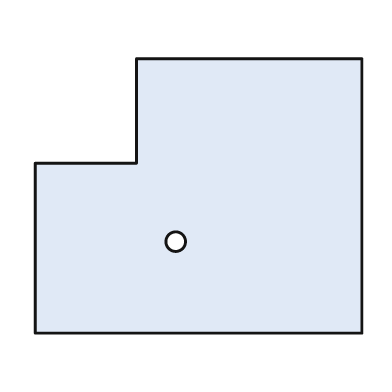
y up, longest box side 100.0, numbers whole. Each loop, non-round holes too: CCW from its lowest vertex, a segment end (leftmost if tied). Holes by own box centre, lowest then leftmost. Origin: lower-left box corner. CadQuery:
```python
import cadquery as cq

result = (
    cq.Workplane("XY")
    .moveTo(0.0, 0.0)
    .lineTo(100.0, 0.0)
    .lineTo(100.0, 84.0)
    .lineTo(31.0, 84.0)
    .lineTo(31.0, 52.0)
    .lineTo(0.0, 52.0)
    .close()
    .moveTo(43.0, 28.0)
    .circle(3.0)
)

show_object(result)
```